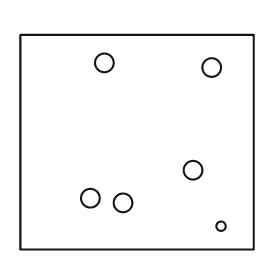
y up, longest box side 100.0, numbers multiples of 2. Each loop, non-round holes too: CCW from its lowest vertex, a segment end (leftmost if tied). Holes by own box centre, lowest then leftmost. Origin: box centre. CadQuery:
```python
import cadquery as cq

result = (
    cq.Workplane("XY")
    .moveTo(-50.0, -46.0)
    .lineTo(50.0, -46.0)
    .lineTo(50.0, 46.0)
    .lineTo(-50.0, 46.0)
    .close()
    .moveTo(36.0, -36.0)
    .circle(2.0)
    .moveTo(-6.0, -26.0)
    .circle(4.0)
    .moveTo(-20.0, -24.0)
    .circle(4.0)
    .moveTo(24.0, -12.0)
    .circle(4.0)
    .moveTo(32.0, 32.0)
    .circle(4.0)
    .moveTo(-14.0, 34.0)
    .circle(4.0)
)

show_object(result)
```